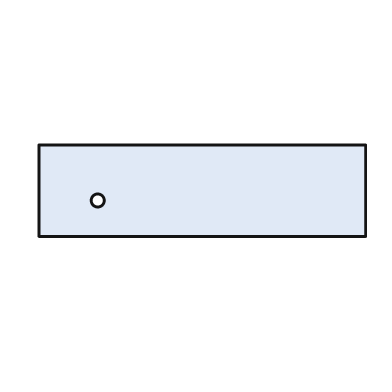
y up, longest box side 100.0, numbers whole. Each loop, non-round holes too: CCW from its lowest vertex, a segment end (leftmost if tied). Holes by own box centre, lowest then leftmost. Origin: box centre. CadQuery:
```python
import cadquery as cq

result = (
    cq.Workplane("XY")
    .moveTo(-50.0, -14.0)
    .lineTo(50.0, -14.0)
    .lineTo(50.0, 14.0)
    .lineTo(-50.0, 14.0)
    .close()
    .moveTo(-32.0, -3.0)
    .circle(2.0)
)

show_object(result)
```